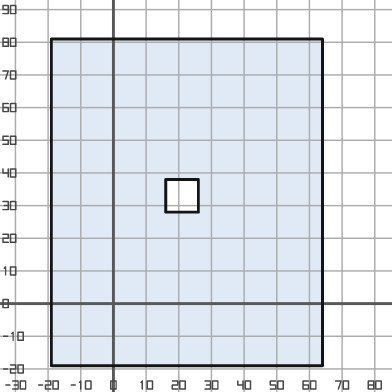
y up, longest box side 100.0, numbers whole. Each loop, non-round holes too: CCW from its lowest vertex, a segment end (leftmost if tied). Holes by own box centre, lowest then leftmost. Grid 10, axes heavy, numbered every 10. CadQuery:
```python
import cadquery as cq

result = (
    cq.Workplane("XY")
    .moveTo(-19.0, -19.0)
    .lineTo(64.0, -19.0)
    .lineTo(64.0, 81.0)
    .lineTo(-19.0, 81.0)
    .close()
    .moveTo(16.0, 28.0)
    .lineTo(26.0, 28.0)
    .lineTo(26.0, 38.0)
    .lineTo(16.0, 38.0)
    .close()
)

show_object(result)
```